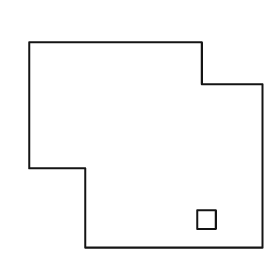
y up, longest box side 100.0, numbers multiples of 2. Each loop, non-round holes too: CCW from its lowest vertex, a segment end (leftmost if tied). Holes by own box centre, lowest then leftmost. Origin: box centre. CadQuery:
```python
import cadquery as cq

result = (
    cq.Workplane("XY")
    .moveTo(-26.0, -44.0)
    .lineTo(50.0, -44.0)
    .lineTo(50.0, 26.0)
    .lineTo(24.0, 26.0)
    .lineTo(24.0, 44.0)
    .lineTo(-50.0, 44.0)
    .lineTo(-50.0, -10.0)
    .lineTo(-26.0, -10.0)
    .close()
    .moveTo(22.0, -36.0)
    .lineTo(30.0, -36.0)
    .lineTo(30.0, -28.0)
    .lineTo(22.0, -28.0)
    .close()
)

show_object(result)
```